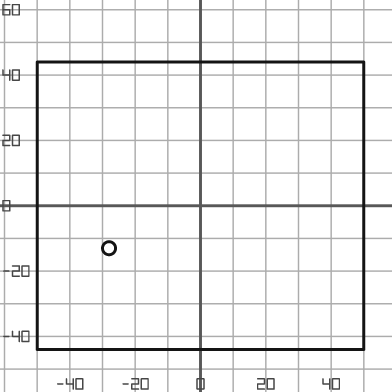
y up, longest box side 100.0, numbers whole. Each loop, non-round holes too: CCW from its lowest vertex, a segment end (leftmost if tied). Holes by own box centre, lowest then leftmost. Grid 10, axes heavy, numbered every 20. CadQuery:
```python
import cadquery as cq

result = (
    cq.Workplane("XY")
    .moveTo(-50.0, -44.0)
    .lineTo(50.0, -44.0)
    .lineTo(50.0, 44.0)
    .lineTo(-50.0, 44.0)
    .close()
    .moveTo(-28.0, -13.0)
    .circle(2.0)
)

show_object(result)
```